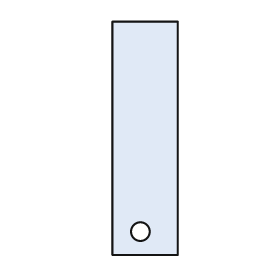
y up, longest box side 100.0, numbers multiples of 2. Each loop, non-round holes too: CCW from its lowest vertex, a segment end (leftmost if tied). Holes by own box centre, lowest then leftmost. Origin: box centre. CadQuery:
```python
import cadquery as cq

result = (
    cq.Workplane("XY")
    .moveTo(-14.0, -50.0)
    .lineTo(14.0, -50.0)
    .lineTo(14.0, 50.0)
    .lineTo(-14.0, 50.0)
    .close()
    .moveTo(-2.0, -40.0)
    .circle(4.0)
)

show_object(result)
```